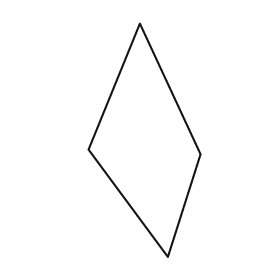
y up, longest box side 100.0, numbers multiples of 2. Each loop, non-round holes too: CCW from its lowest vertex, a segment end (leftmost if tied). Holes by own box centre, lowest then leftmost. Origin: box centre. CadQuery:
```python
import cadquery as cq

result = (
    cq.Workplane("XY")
    .moveTo(10.0, -50.0)
    .lineTo(24.0, -6.0)
    .lineTo(-2.0, 50.0)
    .lineTo(-24.0, -4.0)
    .close()
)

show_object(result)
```